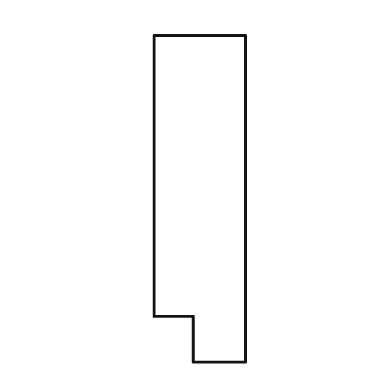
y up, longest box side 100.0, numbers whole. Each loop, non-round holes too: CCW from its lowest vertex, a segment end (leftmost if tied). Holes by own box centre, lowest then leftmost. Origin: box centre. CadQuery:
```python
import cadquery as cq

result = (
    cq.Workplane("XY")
    .moveTo(-2.0, -50.0)
    .lineTo(14.0, -50.0)
    .lineTo(14.0, 50.0)
    .lineTo(-14.0, 50.0)
    .lineTo(-14.0, -36.0)
    .lineTo(-2.0, -36.0)
    .close()
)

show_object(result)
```